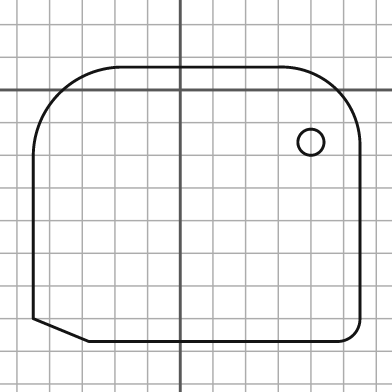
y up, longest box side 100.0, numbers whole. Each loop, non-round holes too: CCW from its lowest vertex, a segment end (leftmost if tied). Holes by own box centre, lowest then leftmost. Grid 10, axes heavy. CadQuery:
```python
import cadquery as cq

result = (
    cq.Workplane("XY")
    .moveTo(-28.0, -77.0)
    .lineTo(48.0, -77.0)
    .threePointArc((53.0, -75.0), (55.0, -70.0))
    .lineTo(55.0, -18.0)
    .threePointArc((48.0, 0.0), (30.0, 7.0))
    .lineTo(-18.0, 7.0)
    .threePointArc((-37.0, -1.0), (-45.0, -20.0))
    .lineTo(-45.0, -70.0)
    .close()
    .moveTo(40.0, -16.0)
    .circle(4.0)
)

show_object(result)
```